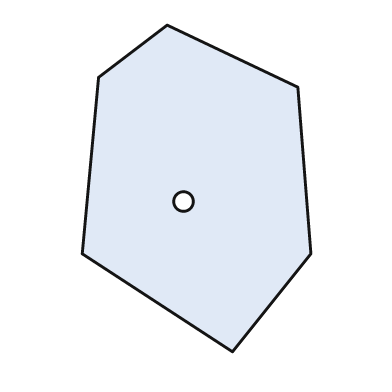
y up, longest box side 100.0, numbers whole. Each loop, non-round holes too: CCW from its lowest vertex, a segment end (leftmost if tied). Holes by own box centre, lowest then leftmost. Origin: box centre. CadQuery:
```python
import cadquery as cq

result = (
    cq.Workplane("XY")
    .moveTo(11.0, -50.0)
    .lineTo(35.0, -20.0)
    .lineTo(31.0, 31.0)
    .lineTo(-9.0, 50.0)
    .lineTo(-30.0, 34.0)
    .lineTo(-35.0, -20.0)
    .close()
    .moveTo(-4.0, -4.0)
    .circle(3.0)
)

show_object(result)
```